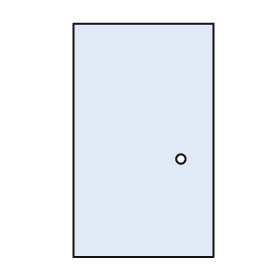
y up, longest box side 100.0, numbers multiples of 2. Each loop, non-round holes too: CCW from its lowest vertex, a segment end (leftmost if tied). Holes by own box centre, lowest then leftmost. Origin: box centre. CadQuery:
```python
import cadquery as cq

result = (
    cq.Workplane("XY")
    .moveTo(-30.0, -50.0)
    .lineTo(30.0, -50.0)
    .lineTo(30.0, 50.0)
    .lineTo(-30.0, 50.0)
    .close()
    .moveTo(16.0, -8.0)
    .circle(2.0)
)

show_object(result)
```